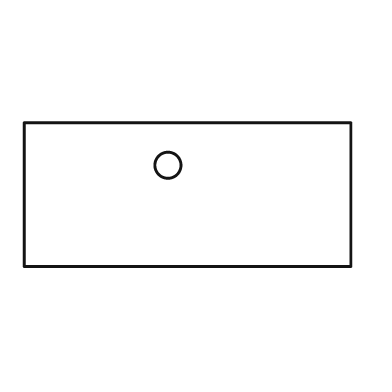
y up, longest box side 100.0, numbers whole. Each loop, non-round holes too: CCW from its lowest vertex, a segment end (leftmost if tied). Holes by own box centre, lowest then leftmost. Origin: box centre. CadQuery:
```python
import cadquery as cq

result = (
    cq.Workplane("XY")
    .moveTo(-50.0, -22.0)
    .lineTo(50.0, -22.0)
    .lineTo(50.0, 22.0)
    .lineTo(-50.0, 22.0)
    .close()
    .moveTo(-6.0, 9.0)
    .circle(4.0)
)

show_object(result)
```